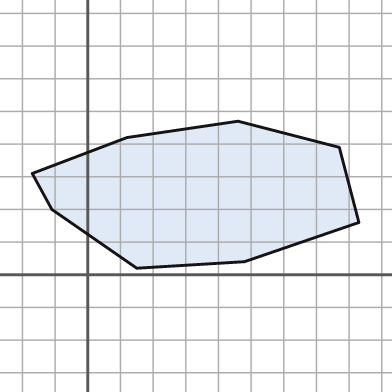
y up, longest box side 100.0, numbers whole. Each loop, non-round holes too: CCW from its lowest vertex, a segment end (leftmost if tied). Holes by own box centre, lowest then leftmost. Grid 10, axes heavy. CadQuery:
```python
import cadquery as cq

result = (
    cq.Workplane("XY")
    .moveTo(15.0, 2.0)
    .lineTo(48.0, 4.0)
    .lineTo(83.0, 16.0)
    .lineTo(77.0, 39.0)
    .lineTo(46.0, 47.0)
    .lineTo(12.0, 42.0)
    .lineTo(-17.0, 31.0)
    .lineTo(-11.0, 20.0)
    .close()
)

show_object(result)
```